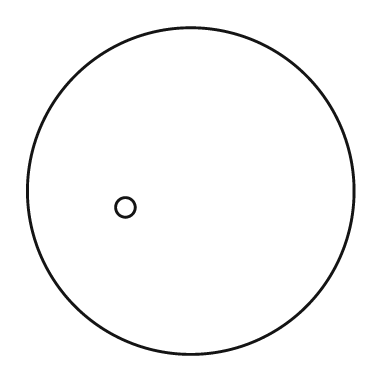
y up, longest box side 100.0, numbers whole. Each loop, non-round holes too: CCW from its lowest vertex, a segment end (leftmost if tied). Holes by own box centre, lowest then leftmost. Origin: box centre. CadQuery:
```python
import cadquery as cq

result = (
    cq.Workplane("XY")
    .moveTo(0.0, 0.0)
    .circle(50.0)
    .moveTo(-20.0, -5.0)
    .circle(3.0)
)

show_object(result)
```